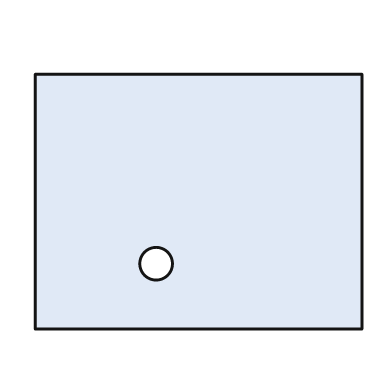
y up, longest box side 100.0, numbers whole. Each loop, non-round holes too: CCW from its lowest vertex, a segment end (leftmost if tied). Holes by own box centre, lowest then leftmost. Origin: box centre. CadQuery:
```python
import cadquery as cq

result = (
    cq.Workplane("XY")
    .moveTo(-50.0, -39.0)
    .lineTo(50.0, -39.0)
    .lineTo(50.0, 39.0)
    .lineTo(-50.0, 39.0)
    .close()
    .moveTo(-13.0, -19.0)
    .circle(5.0)
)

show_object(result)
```